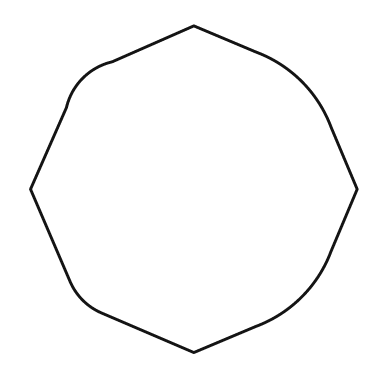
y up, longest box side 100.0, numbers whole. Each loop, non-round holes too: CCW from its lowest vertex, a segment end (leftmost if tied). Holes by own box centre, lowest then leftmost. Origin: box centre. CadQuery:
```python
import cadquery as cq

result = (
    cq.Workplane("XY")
    .moveTo(0.0, -50.0)
    .lineTo(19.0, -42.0)
    .threePointArc((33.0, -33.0), (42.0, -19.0))
    .lineTo(50.0, 0.0)
    .lineTo(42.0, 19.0)
    .threePointArc((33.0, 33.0), (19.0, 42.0))
    .lineTo(0.0, 50.0)
    .lineTo(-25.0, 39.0)
    .threePointArc((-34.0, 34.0), (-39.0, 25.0))
    .lineTo(-50.0, 0.0)
    .lineTo(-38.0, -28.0)
    .threePointArc((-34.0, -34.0), (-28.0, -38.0))
    .close()
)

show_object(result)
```